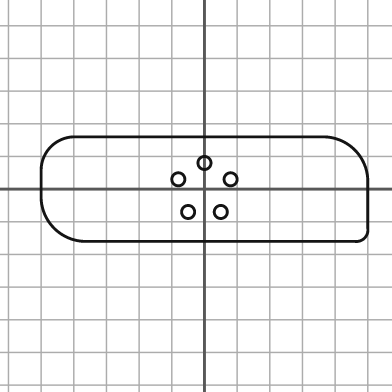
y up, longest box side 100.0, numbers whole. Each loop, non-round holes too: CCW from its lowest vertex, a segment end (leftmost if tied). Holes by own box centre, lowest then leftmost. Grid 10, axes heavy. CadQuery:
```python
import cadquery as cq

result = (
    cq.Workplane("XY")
    .moveTo(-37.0, -16.0)
    .lineTo(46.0, -16.0)
    .threePointArc((49.0, -15.0), (50.0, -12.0))
    .lineTo(50.0, 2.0)
    .threePointArc((46.0, 12.0), (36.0, 16.0))
    .lineTo(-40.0, 16.0)
    .threePointArc((-47.0, 13.0), (-50.0, 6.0))
    .lineTo(-50.0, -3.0)
    .threePointArc((-46.0, -12.0), (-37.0, -16.0))
    .close()
    .moveTo(-5.0, -7.0)
    .circle(2.0)
    .moveTo(5.0, -7.0)
    .circle(2.0)
    .moveTo(-8.0, 3.0)
    .circle(2.0)
    .moveTo(8.0, 3.0)
    .circle(2.0)
    .moveTo(0.0, 8.0)
    .circle(2.0)
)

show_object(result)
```